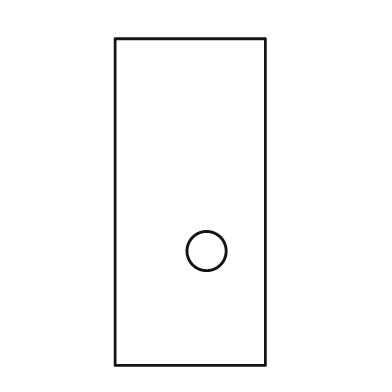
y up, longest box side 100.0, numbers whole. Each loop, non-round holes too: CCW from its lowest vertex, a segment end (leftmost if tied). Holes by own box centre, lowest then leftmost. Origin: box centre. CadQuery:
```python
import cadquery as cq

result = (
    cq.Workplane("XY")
    .moveTo(-23.0, -50.0)
    .lineTo(23.0, -50.0)
    .lineTo(23.0, 50.0)
    .lineTo(-23.0, 50.0)
    .close()
    .moveTo(5.0, -15.0)
    .circle(6.0)
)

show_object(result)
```